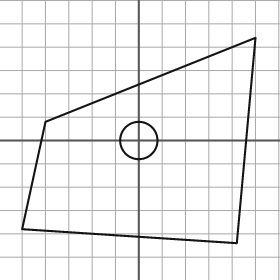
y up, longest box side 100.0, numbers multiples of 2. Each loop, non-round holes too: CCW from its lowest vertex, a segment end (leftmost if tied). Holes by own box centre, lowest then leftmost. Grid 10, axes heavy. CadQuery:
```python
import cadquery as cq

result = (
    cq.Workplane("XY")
    .moveTo(42.0, -44.0)
    .lineTo(50.0, 44.0)
    .lineTo(-40.0, 8.0)
    .lineTo(-50.0, -38.0)
    .close()
    .moveTo(0.0, 0.0)
    .circle(8.0)
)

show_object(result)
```